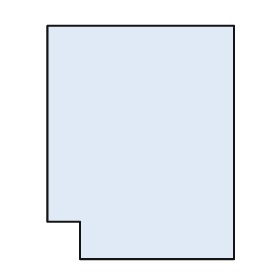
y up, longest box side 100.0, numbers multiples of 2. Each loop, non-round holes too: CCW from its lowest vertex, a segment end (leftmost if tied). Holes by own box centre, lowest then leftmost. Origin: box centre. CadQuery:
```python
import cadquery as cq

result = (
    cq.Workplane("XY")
    .moveTo(-26.0, -50.0)
    .lineTo(40.0, -50.0)
    .lineTo(40.0, 50.0)
    .lineTo(-40.0, 50.0)
    .lineTo(-40.0, -34.0)
    .lineTo(-26.0, -34.0)
    .close()
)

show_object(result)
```